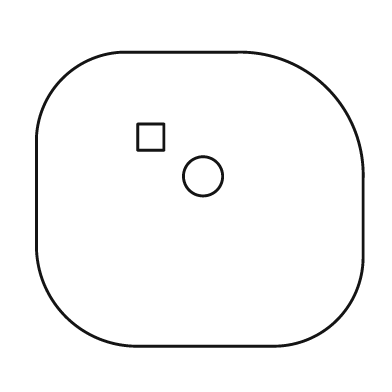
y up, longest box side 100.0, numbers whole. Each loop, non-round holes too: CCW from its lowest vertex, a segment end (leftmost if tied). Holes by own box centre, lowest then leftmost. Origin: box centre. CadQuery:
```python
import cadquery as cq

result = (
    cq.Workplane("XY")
    .moveTo(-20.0, -45.0)
    .lineTo(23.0, -45.0)
    .threePointArc((42.0, -37.0), (50.0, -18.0))
    .lineTo(50.0, 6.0)
    .threePointArc((39.0, 34.0), (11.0, 45.0))
    .lineTo(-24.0, 45.0)
    .threePointArc((-42.0, 37.0), (-50.0, 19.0))
    .lineTo(-50.0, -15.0)
    .threePointArc((-41.0, -36.0), (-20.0, -45.0))
    .close()
    .moveTo(1.0, 7.0)
    .circle(6.0)
    .moveTo(-19.0, 15.0)
    .lineTo(-11.0, 15.0)
    .lineTo(-11.0, 23.0)
    .lineTo(-19.0, 23.0)
    .close()
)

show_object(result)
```